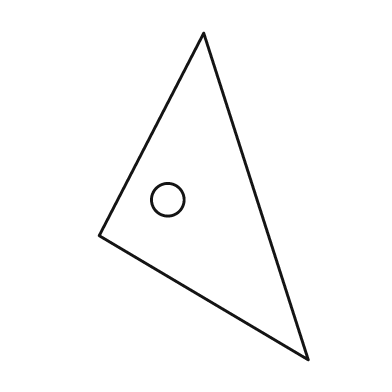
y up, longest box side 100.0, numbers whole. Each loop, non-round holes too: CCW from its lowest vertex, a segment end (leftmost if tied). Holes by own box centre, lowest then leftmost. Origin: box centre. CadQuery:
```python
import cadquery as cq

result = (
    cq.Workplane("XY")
    .moveTo(32.0, -50.0)
    .lineTo(0.0, 50.0)
    .lineTo(-32.0, -12.0)
    .close()
    .moveTo(-11.0, -1.0)
    .circle(5.0)
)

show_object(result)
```